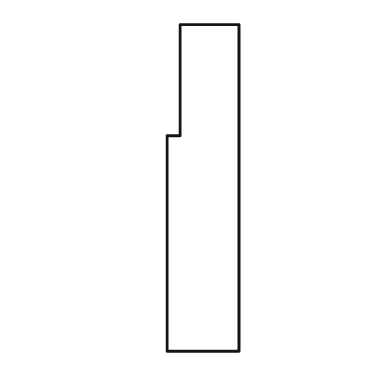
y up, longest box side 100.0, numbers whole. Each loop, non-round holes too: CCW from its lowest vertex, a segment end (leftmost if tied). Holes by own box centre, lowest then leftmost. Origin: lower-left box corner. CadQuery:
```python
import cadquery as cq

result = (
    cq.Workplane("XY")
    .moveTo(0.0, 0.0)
    .lineTo(22.0, 0.0)
    .lineTo(22.0, 100.0)
    .lineTo(4.0, 100.0)
    .lineTo(4.0, 66.0)
    .lineTo(0.0, 66.0)
    .close()
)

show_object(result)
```